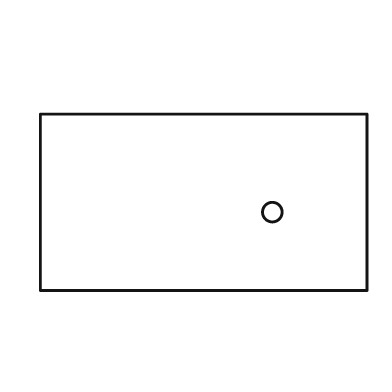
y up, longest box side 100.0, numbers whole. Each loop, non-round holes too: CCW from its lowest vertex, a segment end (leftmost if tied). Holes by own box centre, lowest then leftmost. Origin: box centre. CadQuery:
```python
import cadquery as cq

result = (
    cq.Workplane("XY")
    .moveTo(-50.0, -27.0)
    .lineTo(50.0, -27.0)
    .lineTo(50.0, 27.0)
    .lineTo(-50.0, 27.0)
    .close()
    .moveTo(21.0, -3.0)
    .circle(3.0)
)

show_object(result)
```